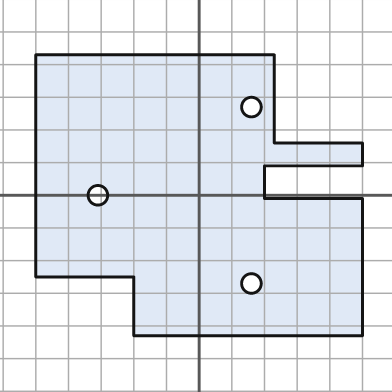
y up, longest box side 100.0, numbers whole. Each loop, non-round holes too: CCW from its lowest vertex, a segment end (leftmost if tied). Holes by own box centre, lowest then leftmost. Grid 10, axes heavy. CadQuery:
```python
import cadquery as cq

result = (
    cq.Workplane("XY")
    .moveTo(-20.0, -43.0)
    .lineTo(50.0, -43.0)
    .lineTo(50.0, -1.0)
    .lineTo(20.0, -1.0)
    .lineTo(20.0, 9.0)
    .lineTo(50.0, 9.0)
    .lineTo(50.0, 16.0)
    .lineTo(23.0, 16.0)
    .lineTo(23.0, 43.0)
    .lineTo(-50.0, 43.0)
    .lineTo(-50.0, -25.0)
    .lineTo(-20.0, -25.0)
    .close()
    .moveTo(16.0, -27.0)
    .circle(3.0)
    .moveTo(-31.0, 0.0)
    .circle(3.0)
    .moveTo(16.0, 27.0)
    .circle(3.0)
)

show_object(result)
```